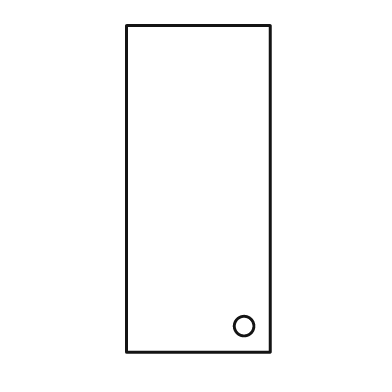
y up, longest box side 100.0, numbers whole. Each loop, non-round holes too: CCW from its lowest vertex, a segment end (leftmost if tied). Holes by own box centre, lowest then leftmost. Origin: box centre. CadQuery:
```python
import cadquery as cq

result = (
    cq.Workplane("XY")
    .moveTo(-22.0, -50.0)
    .lineTo(22.0, -50.0)
    .lineTo(22.0, 50.0)
    .lineTo(-22.0, 50.0)
    .close()
    .moveTo(14.0, -42.0)
    .circle(3.0)
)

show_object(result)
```